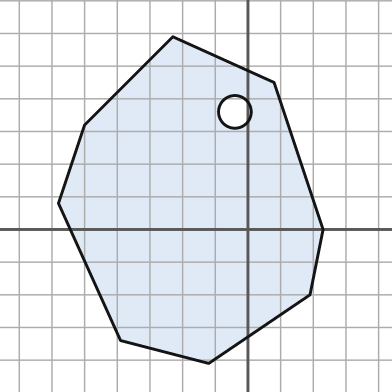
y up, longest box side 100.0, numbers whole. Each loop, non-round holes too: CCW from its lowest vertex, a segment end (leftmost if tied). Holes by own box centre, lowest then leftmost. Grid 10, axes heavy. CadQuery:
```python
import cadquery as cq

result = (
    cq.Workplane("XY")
    .moveTo(-12.0, -41.0)
    .lineTo(19.0, -20.0)
    .lineTo(23.0, 0.0)
    .lineTo(8.0, 45.0)
    .lineTo(-23.0, 59.0)
    .lineTo(-50.0, 32.0)
    .lineTo(-58.0, 8.0)
    .lineTo(-39.0, -34.0)
    .close()
    .moveTo(-4.0, 36.0)
    .circle(5.0)
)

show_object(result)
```